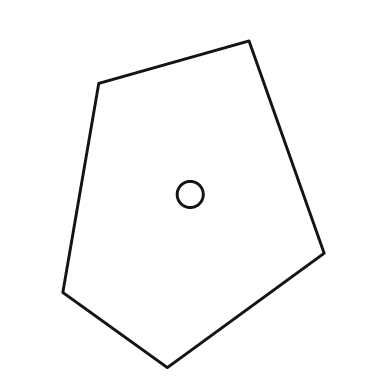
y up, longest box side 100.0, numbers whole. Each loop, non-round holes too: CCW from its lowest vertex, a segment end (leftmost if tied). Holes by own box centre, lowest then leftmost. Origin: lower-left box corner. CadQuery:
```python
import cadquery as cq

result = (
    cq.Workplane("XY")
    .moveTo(32.0, 0.0)
    .lineTo(80.0, 35.0)
    .lineTo(57.0, 100.0)
    .lineTo(11.0, 87.0)
    .lineTo(0.0, 23.0)
    .close()
    .moveTo(39.0, 53.0)
    .circle(4.0)
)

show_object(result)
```